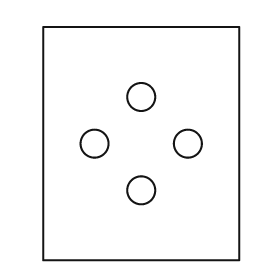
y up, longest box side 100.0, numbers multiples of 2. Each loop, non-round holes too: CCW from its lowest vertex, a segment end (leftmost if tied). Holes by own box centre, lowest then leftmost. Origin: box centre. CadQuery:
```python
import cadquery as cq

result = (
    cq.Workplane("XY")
    .moveTo(-42.0, -50.0)
    .lineTo(42.0, -50.0)
    .lineTo(42.0, 50.0)
    .lineTo(-42.0, 50.0)
    .close()
    .moveTo(0.0, -20.0)
    .circle(6.0)
    .moveTo(-20.0, 0.0)
    .circle(6.0)
    .moveTo(20.0, 0.0)
    .circle(6.0)
    .moveTo(0.0, 20.0)
    .circle(6.0)
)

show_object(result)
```